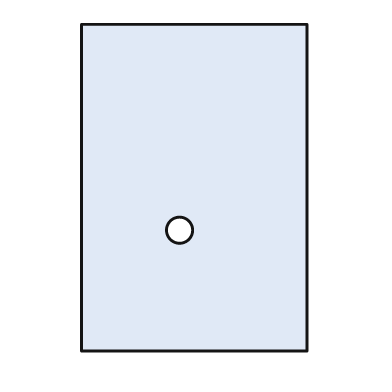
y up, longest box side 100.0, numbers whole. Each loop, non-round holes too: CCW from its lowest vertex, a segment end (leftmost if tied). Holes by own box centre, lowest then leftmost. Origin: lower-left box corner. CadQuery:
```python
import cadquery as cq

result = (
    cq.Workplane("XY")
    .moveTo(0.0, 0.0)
    .lineTo(69.0, 0.0)
    .lineTo(69.0, 100.0)
    .lineTo(0.0, 100.0)
    .close()
    .moveTo(30.0, 37.0)
    .circle(4.0)
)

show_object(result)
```